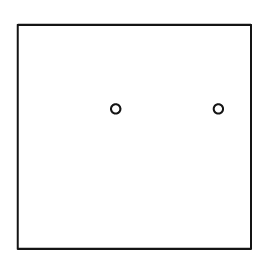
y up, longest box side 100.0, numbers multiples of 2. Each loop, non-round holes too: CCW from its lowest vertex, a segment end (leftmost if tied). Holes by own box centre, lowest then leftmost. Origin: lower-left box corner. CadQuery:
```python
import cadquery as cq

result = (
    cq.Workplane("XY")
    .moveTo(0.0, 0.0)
    .lineTo(100.0, 0.0)
    .lineTo(100.0, 96.0)
    .lineTo(0.0, 96.0)
    .close()
    .moveTo(42.0, 60.0)
    .circle(2.0)
    .moveTo(86.0, 60.0)
    .circle(2.0)
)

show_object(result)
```